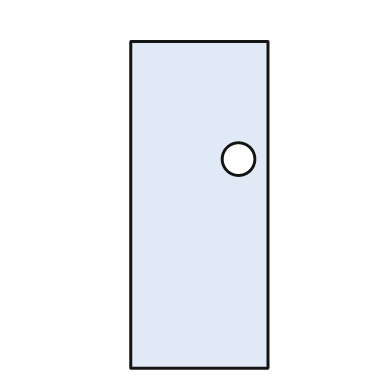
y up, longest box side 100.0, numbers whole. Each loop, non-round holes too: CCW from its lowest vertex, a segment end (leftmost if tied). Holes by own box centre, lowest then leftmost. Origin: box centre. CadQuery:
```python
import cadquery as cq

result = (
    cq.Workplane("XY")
    .moveTo(-21.0, -50.0)
    .lineTo(21.0, -50.0)
    .lineTo(21.0, 50.0)
    .lineTo(-21.0, 50.0)
    .close()
    .moveTo(12.0, 14.0)
    .circle(5.0)
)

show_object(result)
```